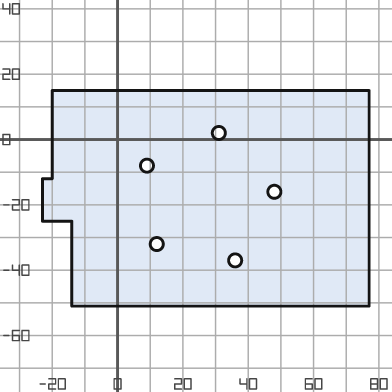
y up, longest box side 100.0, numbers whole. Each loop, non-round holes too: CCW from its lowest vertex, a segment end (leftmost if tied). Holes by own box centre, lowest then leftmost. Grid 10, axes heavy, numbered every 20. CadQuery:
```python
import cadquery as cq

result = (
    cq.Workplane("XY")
    .moveTo(-14.0, -51.0)
    .lineTo(77.0, -51.0)
    .lineTo(77.0, 15.0)
    .lineTo(-20.0, 15.0)
    .lineTo(-20.0, -12.0)
    .lineTo(-23.0, -12.0)
    .lineTo(-23.0, -25.0)
    .lineTo(-14.0, -25.0)
    .close()
    .moveTo(36.0, -37.0)
    .circle(2.0)
    .moveTo(12.0, -32.0)
    .circle(2.0)
    .moveTo(48.0, -16.0)
    .circle(2.0)
    .moveTo(9.0, -8.0)
    .circle(2.0)
    .moveTo(31.0, 2.0)
    .circle(2.0)
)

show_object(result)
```